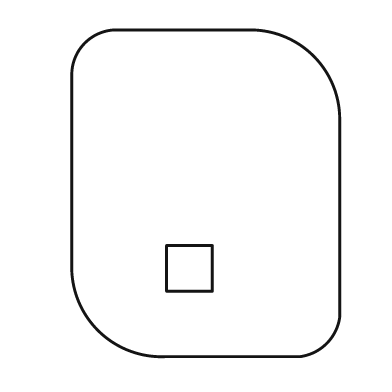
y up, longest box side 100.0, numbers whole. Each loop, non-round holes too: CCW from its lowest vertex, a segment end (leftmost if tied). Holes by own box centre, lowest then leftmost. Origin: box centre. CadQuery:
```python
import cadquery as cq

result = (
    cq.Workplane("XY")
    .moveTo(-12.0, -50.0)
    .lineTo(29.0, -50.0)
    .threePointArc((37.0, -46.0), (41.0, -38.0))
    .lineTo(41.0, 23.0)
    .threePointArc((33.0, 42.0), (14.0, 50.0))
    .lineTo(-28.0, 50.0)
    .threePointArc((-37.0, 46.0), (-41.0, 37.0))
    .lineTo(-41.0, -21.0)
    .threePointArc((-33.0, -42.0), (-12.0, -50.0))
    .close()
    .moveTo(-12.0, -30.0)
    .lineTo(2.0, -30.0)
    .lineTo(2.0, -16.0)
    .lineTo(-12.0, -16.0)
    .close()
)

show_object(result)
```